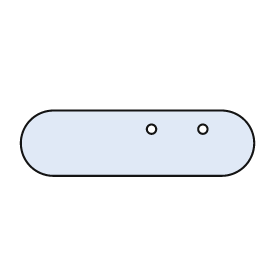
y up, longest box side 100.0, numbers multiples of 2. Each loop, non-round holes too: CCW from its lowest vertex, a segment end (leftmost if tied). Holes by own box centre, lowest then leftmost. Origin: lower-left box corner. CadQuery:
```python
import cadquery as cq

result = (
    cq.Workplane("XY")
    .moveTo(14.0, 0.0)
    .lineTo(86.0, 0.0)
    .threePointArc((100.0, 14.0), (86.0, 28.0))
    .lineTo(14.0, 28.0)
    .threePointArc((0.0, 14.0), (14.0, 0.0))
    .close()
    .moveTo(56.0, 20.0)
    .circle(2.0)
    .moveTo(78.0, 20.0)
    .circle(2.0)
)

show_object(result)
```